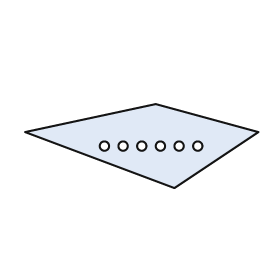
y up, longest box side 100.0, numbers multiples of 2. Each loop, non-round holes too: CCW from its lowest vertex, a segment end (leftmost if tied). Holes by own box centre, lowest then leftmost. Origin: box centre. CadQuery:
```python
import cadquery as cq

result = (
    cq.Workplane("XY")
    .moveTo(14.0, -18.0)
    .lineTo(50.0, 6.0)
    .lineTo(6.0, 18.0)
    .lineTo(-50.0, 6.0)
    .close()
    .moveTo(-16.0, 0.0)
    .circle(2.0)
    .moveTo(-8.0, 0.0)
    .circle(2.0)
    .moveTo(0.0, 0.0)
    .circle(2.0)
    .moveTo(8.0, 0.0)
    .circle(2.0)
    .moveTo(16.0, 0.0)
    .circle(2.0)
    .moveTo(24.0, 0.0)
    .circle(2.0)
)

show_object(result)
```